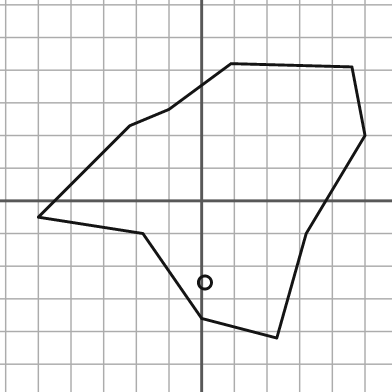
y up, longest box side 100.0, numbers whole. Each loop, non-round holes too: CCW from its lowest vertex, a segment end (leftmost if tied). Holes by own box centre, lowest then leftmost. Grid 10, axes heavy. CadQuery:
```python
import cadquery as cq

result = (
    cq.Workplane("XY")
    .moveTo(23.0, -42.0)
    .lineTo(32.0, -10.0)
    .lineTo(50.0, 20.0)
    .lineTo(46.0, 41.0)
    .lineTo(9.0, 42.0)
    .lineTo(-10.0, 28.0)
    .lineTo(-22.0, 23.0)
    .lineTo(-50.0, -5.0)
    .lineTo(-18.0, -10.0)
    .lineTo(0.0, -36.0)
    .close()
    .moveTo(1.0, -25.0)
    .circle(2.0)
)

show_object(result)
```